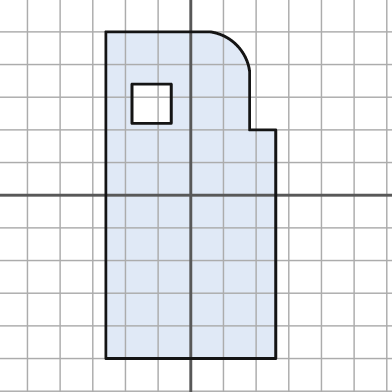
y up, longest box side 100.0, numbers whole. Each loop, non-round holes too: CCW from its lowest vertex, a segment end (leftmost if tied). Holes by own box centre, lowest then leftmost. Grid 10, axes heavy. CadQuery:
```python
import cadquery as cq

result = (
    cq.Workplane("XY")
    .moveTo(-26.0, -50.0)
    .lineTo(26.0, -50.0)
    .lineTo(26.0, 20.0)
    .lineTo(18.0, 20.0)
    .lineTo(18.0, 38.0)
    .threePointArc((14.0, 46.0), (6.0, 50.0))
    .lineTo(-26.0, 50.0)
    .close()
    .moveTo(-18.0, 22.0)
    .lineTo(-6.0, 22.0)
    .lineTo(-6.0, 34.0)
    .lineTo(-18.0, 34.0)
    .close()
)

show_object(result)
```